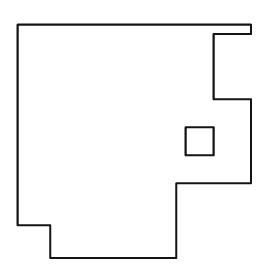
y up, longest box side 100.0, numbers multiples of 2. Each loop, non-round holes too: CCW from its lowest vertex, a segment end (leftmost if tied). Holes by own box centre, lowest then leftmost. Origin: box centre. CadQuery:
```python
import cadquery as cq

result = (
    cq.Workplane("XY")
    .moveTo(-36.0, -50.0)
    .lineTo(18.0, -50.0)
    .lineTo(18.0, -18.0)
    .lineTo(50.0, -18.0)
    .lineTo(50.0, 18.0)
    .lineTo(34.0, 18.0)
    .lineTo(34.0, 46.0)
    .lineTo(50.0, 46.0)
    .lineTo(50.0, 50.0)
    .lineTo(-50.0, 50.0)
    .lineTo(-50.0, -36.0)
    .lineTo(-36.0, -36.0)
    .close()
    .moveTo(22.0, -6.0)
    .lineTo(34.0, -6.0)
    .lineTo(34.0, 6.0)
    .lineTo(22.0, 6.0)
    .close()
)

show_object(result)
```